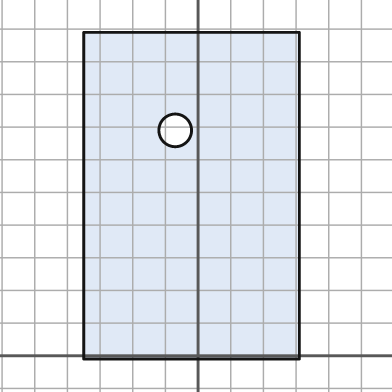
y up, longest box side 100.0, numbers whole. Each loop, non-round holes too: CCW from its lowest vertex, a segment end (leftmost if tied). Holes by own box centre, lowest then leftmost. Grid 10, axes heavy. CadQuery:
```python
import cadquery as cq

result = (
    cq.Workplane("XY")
    .moveTo(-35.0, -1.0)
    .lineTo(31.0, -1.0)
    .lineTo(31.0, 99.0)
    .lineTo(-35.0, 99.0)
    .close()
    .moveTo(-7.0, 69.0)
    .circle(5.0)
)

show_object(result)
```